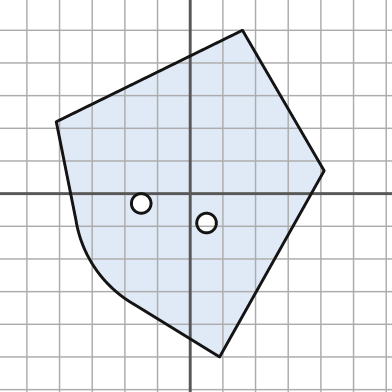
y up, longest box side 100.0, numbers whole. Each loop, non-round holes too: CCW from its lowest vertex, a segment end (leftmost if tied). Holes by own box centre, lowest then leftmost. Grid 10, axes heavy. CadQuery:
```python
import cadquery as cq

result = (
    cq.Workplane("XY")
    .moveTo(9.0, -50.0)
    .lineTo(41.0, 7.0)
    .lineTo(16.0, 50.0)
    .lineTo(-41.0, 22.0)
    .lineTo(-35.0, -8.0)
    .threePointArc((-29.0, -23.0), (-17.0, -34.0))
    .close()
    .moveTo(5.0, -9.0)
    .circle(3.0)
    .moveTo(-15.0, -3.0)
    .circle(3.0)
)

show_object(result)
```